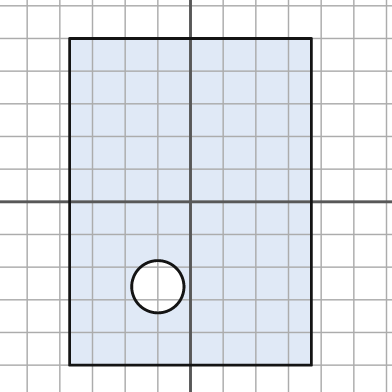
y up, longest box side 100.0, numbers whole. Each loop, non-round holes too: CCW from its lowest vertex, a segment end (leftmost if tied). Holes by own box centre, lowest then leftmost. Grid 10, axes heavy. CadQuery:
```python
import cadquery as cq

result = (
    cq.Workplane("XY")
    .moveTo(-37.0, -50.0)
    .lineTo(37.0, -50.0)
    .lineTo(37.0, 50.0)
    .lineTo(-37.0, 50.0)
    .close()
    .moveTo(-10.0, -26.0)
    .circle(8.0)
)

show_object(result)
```